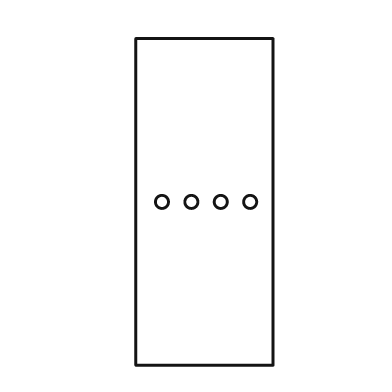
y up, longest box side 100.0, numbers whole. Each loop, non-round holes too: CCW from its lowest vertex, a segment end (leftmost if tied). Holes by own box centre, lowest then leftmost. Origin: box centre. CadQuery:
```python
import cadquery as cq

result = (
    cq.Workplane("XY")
    .moveTo(-21.0, -50.0)
    .lineTo(21.0, -50.0)
    .lineTo(21.0, 50.0)
    .lineTo(-21.0, 50.0)
    .close()
    .moveTo(-13.0, 0.0)
    .circle(2.0)
    .moveTo(-4.0, 0.0)
    .circle(2.0)
    .moveTo(5.0, 0.0)
    .circle(2.0)
    .moveTo(14.0, 0.0)
    .circle(2.0)
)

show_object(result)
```